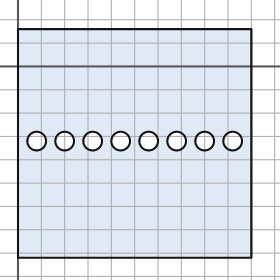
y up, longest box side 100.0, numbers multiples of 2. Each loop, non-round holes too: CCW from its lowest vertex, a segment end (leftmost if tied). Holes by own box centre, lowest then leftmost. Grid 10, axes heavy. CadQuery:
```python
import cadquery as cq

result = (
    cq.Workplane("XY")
    .moveTo(0.0, -82.0)
    .lineTo(100.0, -82.0)
    .lineTo(100.0, 16.0)
    .lineTo(0.0, 16.0)
    .close()
    .moveTo(8.0, -32.0)
    .circle(4.0)
    .moveTo(20.0, -32.0)
    .circle(4.0)
    .moveTo(32.0, -32.0)
    .circle(4.0)
    .moveTo(44.0, -32.0)
    .circle(4.0)
    .moveTo(56.0, -32.0)
    .circle(4.0)
    .moveTo(68.0, -32.0)
    .circle(4.0)
    .moveTo(80.0, -32.0)
    .circle(4.0)
    .moveTo(92.0, -32.0)
    .circle(4.0)
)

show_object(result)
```